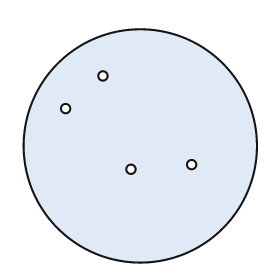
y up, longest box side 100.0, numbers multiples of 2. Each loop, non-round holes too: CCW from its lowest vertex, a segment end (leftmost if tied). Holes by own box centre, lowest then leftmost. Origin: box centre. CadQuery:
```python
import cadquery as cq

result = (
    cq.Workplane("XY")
    .moveTo(0.0, 0.0)
    .circle(50.0)
    .moveTo(-4.0, -10.0)
    .circle(2.0)
    .moveTo(22.0, -8.0)
    .circle(2.0)
    .moveTo(-32.0, 16.0)
    .circle(2.0)
    .moveTo(-16.0, 30.0)
    .circle(2.0)
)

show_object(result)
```